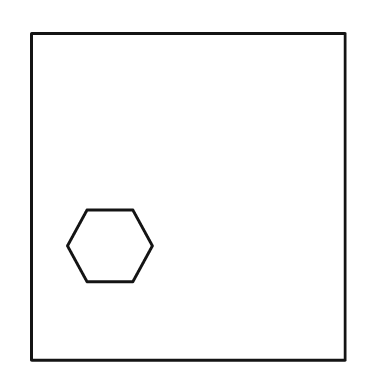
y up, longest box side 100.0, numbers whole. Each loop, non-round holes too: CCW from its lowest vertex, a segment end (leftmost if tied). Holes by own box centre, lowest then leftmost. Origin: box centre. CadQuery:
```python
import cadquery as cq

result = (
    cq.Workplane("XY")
    .moveTo(-48.0, -50.0)
    .lineTo(48.0, -50.0)
    .lineTo(48.0, 50.0)
    .lineTo(-48.0, 50.0)
    .close()
    .moveTo(-31.0, -26.0)
    .lineTo(-17.0, -26.0)
    .lineTo(-11.0, -15.0)
    .lineTo(-17.0, -4.0)
    .lineTo(-31.0, -4.0)
    .lineTo(-37.0, -15.0)
    .close()
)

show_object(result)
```